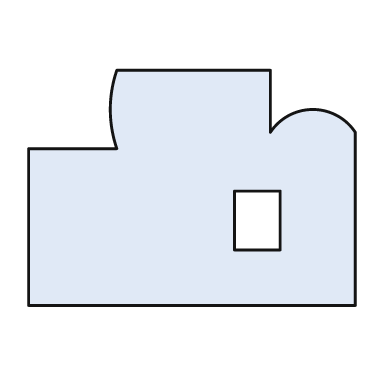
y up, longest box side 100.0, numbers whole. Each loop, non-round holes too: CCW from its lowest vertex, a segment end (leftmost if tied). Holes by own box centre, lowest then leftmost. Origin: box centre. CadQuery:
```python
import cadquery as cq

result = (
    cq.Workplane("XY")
    .moveTo(-50.0, -36.0)
    .lineTo(50.0, -36.0)
    .lineTo(50.0, 17.0)
    .threePointArc((37.0, 24.0), (24.0, 17.0))
    .lineTo(24.0, 36.0)
    .lineTo(-23.0, 36.0)
    .threePointArc((-25.0, 24.0), (-23.0, 12.0))
    .lineTo(-50.0, 12.0)
    .close()
    .moveTo(13.0, -19.0)
    .lineTo(27.0, -19.0)
    .lineTo(27.0, -1.0)
    .lineTo(13.0, -1.0)
    .close()
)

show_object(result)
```